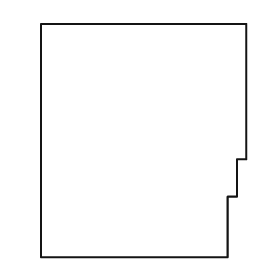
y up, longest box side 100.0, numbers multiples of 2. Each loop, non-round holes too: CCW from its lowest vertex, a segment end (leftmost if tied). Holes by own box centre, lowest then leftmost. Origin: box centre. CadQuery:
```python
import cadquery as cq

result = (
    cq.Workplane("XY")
    .moveTo(-44.0, -50.0)
    .lineTo(36.0, -50.0)
    .lineTo(36.0, -24.0)
    .lineTo(40.0, -24.0)
    .lineTo(40.0, -8.0)
    .lineTo(44.0, -8.0)
    .lineTo(44.0, 50.0)
    .lineTo(-44.0, 50.0)
    .close()
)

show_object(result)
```